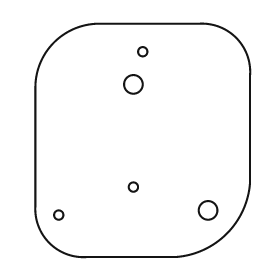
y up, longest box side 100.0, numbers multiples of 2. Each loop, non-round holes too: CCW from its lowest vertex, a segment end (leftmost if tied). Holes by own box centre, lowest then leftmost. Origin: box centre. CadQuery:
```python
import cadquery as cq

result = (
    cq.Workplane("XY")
    .moveTo(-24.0, -50.0)
    .lineTo(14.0, -50.0)
    .threePointArc((36.0, -40.0), (46.0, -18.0))
    .lineTo(46.0, 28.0)
    .threePointArc((40.0, 44.0), (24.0, 50.0))
    .lineTo(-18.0, 50.0)
    .threePointArc((-38.0, 42.0), (-46.0, 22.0))
    .lineTo(-46.0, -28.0)
    .threePointArc((-40.0, -44.0), (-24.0, -50.0))
    .close()
    .moveTo(-36.0, -32.0)
    .circle(2.0)
    .moveTo(28.0, -30.0)
    .circle(4.0)
    .moveTo(-4.0, -20.0)
    .circle(2.0)
    .moveTo(-4.0, 24.0)
    .circle(4.0)
    .moveTo(0.0, 38.0)
    .circle(2.0)
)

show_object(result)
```